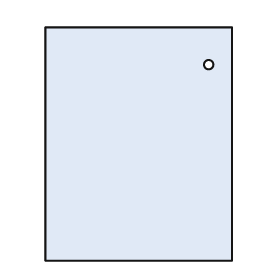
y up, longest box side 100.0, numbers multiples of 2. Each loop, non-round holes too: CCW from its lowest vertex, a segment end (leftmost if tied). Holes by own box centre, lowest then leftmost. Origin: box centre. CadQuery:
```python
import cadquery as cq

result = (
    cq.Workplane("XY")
    .moveTo(-40.0, -50.0)
    .lineTo(40.0, -50.0)
    .lineTo(40.0, 50.0)
    .lineTo(-40.0, 50.0)
    .close()
    .moveTo(30.0, 34.0)
    .circle(2.0)
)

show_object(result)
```